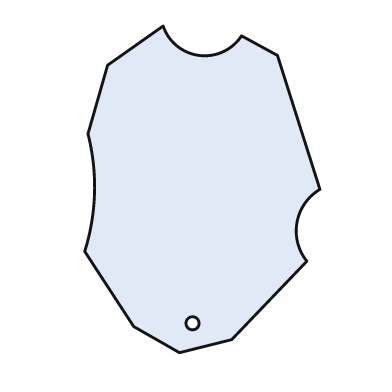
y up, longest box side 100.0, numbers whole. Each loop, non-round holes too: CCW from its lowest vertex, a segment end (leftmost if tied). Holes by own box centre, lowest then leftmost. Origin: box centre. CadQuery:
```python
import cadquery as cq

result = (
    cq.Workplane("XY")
    .moveTo(-7.0, -50.0)
    .lineTo(9.0, -46.0)
    .lineTo(32.0, -22.0)
    .threePointArc((29.0, -10.0), (36.0, 0.0))
    .lineTo(23.0, 41.0)
    .lineTo(12.0, 47.0)
    .threePointArc((-1.0, 41.0), (-12.0, 50.0))
    .lineTo(-29.0, 38.0)
    .lineTo(-35.0, 17.0)
    .threePointArc((-33.0, -1.0), (-36.0, -19.0))
    .lineTo(-21.0, -42.0)
    .close()
    .moveTo(-3.0, -41.0)
    .circle(2.0)
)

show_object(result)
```